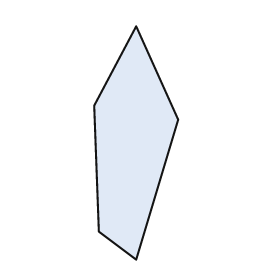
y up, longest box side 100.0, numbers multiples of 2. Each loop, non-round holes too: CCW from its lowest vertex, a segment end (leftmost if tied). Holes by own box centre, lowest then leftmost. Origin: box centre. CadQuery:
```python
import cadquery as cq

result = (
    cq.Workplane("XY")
    .moveTo(0.0, -50.0)
    .lineTo(18.0, 10.0)
    .lineTo(0.0, 50.0)
    .lineTo(-18.0, 16.0)
    .lineTo(-16.0, -38.0)
    .close()
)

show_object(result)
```